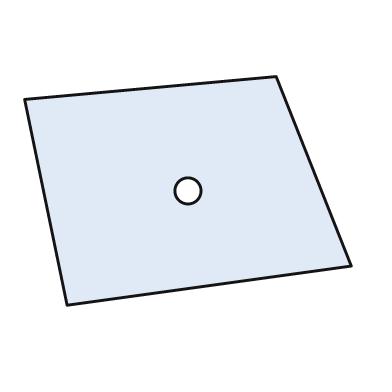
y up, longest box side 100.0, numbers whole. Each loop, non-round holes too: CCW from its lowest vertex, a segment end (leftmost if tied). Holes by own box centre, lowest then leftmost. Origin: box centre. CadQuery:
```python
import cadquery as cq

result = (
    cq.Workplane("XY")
    .moveTo(-37.0, -35.0)
    .lineTo(50.0, -23.0)
    .lineTo(27.0, 35.0)
    .lineTo(-50.0, 28.0)
    .close()
    .moveTo(0.0, 0.0)
    .circle(4.0)
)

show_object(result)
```